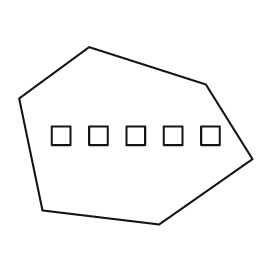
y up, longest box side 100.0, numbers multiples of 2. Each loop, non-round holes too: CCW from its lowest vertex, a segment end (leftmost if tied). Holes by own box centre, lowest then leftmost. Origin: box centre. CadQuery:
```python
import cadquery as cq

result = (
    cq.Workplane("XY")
    .moveTo(10.0, -38.0)
    .lineTo(50.0, -10.0)
    .lineTo(30.0, 22.0)
    .lineTo(-20.0, 38.0)
    .lineTo(-50.0, 16.0)
    .lineTo(-40.0, -32.0)
    .close()
    .moveTo(-36.0, -4.0)
    .lineTo(-28.0, -4.0)
    .lineTo(-28.0, 4.0)
    .lineTo(-36.0, 4.0)
    .close()
    .moveTo(-20.0, -4.0)
    .lineTo(-12.0, -4.0)
    .lineTo(-12.0, 4.0)
    .lineTo(-20.0, 4.0)
    .close()
    .moveTo(-4.0, -4.0)
    .lineTo(4.0, -4.0)
    .lineTo(4.0, 4.0)
    .lineTo(-4.0, 4.0)
    .close()
    .moveTo(12.0, -4.0)
    .lineTo(20.0, -4.0)
    .lineTo(20.0, 4.0)
    .lineTo(12.0, 4.0)
    .close()
    .moveTo(28.0, -4.0)
    .lineTo(36.0, -4.0)
    .lineTo(36.0, 4.0)
    .lineTo(28.0, 4.0)
    .close()
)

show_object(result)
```